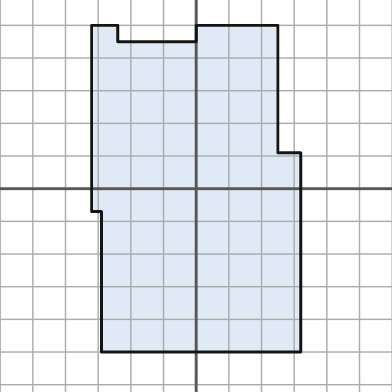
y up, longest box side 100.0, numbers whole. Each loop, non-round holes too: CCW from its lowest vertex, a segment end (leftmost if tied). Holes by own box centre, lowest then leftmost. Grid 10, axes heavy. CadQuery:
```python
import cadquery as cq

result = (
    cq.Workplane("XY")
    .moveTo(-29.0, -50.0)
    .lineTo(32.0, -50.0)
    .lineTo(32.0, 11.0)
    .lineTo(25.0, 11.0)
    .lineTo(25.0, 50.0)
    .lineTo(0.0, 50.0)
    .lineTo(0.0, 45.0)
    .lineTo(-24.0, 45.0)
    .lineTo(-24.0, 50.0)
    .lineTo(-32.0, 50.0)
    .lineTo(-32.0, -7.0)
    .lineTo(-29.0, -7.0)
    .close()
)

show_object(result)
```